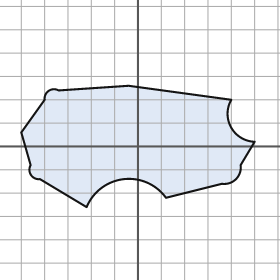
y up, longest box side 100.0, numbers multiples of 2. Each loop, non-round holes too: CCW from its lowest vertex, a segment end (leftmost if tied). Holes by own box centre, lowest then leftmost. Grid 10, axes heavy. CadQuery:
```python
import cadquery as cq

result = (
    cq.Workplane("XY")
    .moveTo(-22.0, -26.0)
    .threePointArc((-6.0, -14.0), (12.0, -22.0))
    .lineTo(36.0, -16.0)
    .threePointArc((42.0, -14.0), (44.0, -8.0))
    .lineTo(50.0, 2.0)
    .threePointArc((40.0, 8.0), (40.0, 20.0))
    .lineTo(-4.0, 26.0)
    .lineTo(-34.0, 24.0)
    .threePointArc((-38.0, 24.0), (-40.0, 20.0))
    .lineTo(-50.0, 6.0)
    .lineTo(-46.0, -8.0)
    .threePointArc((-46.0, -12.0), (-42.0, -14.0))
    .close()
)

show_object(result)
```